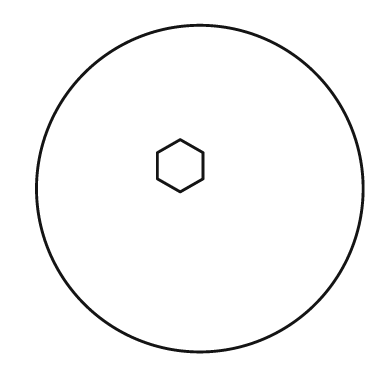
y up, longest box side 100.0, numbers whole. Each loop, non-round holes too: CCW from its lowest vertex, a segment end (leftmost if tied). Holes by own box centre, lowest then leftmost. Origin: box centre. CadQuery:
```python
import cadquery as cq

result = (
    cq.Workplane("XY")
    .moveTo(0.0, 0.0)
    .circle(50.0)
    .moveTo(-6.0, -1.0)
    .lineTo(1.0, 3.0)
    .lineTo(1.0, 11.0)
    .lineTo(-6.0, 15.0)
    .lineTo(-13.0, 11.0)
    .lineTo(-13.0, 3.0)
    .close()
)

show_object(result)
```